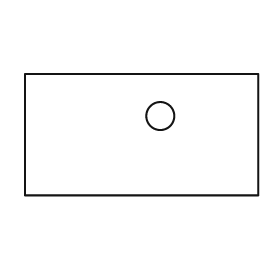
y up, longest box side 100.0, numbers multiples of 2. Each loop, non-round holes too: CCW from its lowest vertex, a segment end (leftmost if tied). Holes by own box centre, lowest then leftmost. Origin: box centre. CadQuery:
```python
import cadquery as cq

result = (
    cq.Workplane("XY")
    .moveTo(-50.0, -26.0)
    .lineTo(50.0, -26.0)
    .lineTo(50.0, 26.0)
    .lineTo(-50.0, 26.0)
    .close()
    .moveTo(8.0, 8.0)
    .circle(6.0)
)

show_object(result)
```